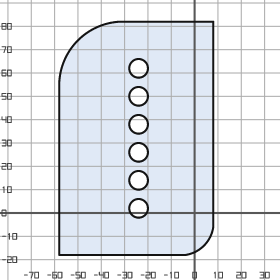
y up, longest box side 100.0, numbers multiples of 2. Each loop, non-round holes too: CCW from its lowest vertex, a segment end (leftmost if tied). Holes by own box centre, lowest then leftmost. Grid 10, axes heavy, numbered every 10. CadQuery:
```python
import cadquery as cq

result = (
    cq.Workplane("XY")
    .moveTo(-58.0, -18.0)
    .lineTo(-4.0, -18.0)
    .threePointArc((4.0, -14.0), (8.0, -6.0))
    .lineTo(8.0, 82.0)
    .lineTo(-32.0, 82.0)
    .threePointArc((-50.0, 74.0), (-58.0, 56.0))
    .close()
    .moveTo(-24.0, 2.0)
    .circle(4.0)
    .moveTo(-24.0, 14.0)
    .circle(4.0)
    .moveTo(-24.0, 26.0)
    .circle(4.0)
    .moveTo(-24.0, 38.0)
    .circle(4.0)
    .moveTo(-24.0, 50.0)
    .circle(4.0)
    .moveTo(-24.0, 62.0)
    .circle(4.0)
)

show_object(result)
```